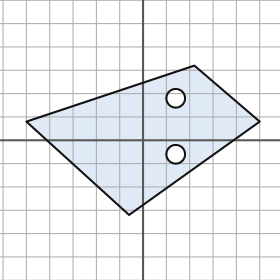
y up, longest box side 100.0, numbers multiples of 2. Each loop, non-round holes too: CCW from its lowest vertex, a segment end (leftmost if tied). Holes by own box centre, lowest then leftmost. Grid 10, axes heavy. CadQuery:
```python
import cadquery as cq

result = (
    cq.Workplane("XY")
    .moveTo(-6.0, -32.0)
    .lineTo(50.0, 8.0)
    .lineTo(22.0, 32.0)
    .lineTo(-50.0, 8.0)
    .close()
    .moveTo(14.0, -6.0)
    .circle(4.0)
    .moveTo(14.0, 18.0)
    .circle(4.0)
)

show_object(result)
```